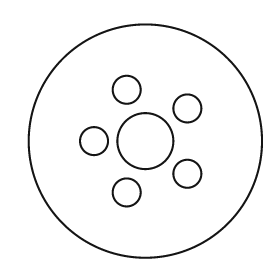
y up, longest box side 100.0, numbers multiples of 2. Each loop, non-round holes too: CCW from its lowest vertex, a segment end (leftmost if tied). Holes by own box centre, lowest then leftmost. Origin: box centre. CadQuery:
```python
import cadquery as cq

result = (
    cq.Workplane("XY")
    .moveTo(0.0, 0.0)
    .circle(50.0)
    .moveTo(-8.0, -22.0)
    .circle(6.0)
    .moveTo(18.0, -14.0)
    .circle(6.0)
    .moveTo(-22.0, 0.0)
    .circle(6.0)
    .moveTo(0.0, 0.0)
    .circle(12.0)
    .moveTo(18.0, 14.0)
    .circle(6.0)
    .moveTo(-8.0, 22.0)
    .circle(6.0)
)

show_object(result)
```